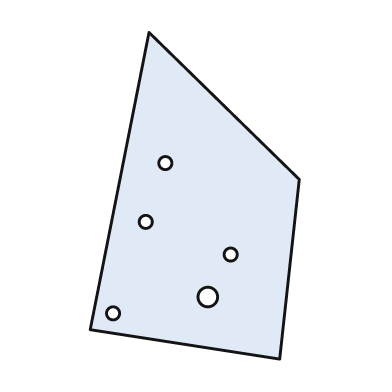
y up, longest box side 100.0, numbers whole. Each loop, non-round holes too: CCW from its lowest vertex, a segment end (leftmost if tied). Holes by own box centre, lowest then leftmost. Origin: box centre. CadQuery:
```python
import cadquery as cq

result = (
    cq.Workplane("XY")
    .moveTo(26.0, -50.0)
    .lineTo(32.0, 5.0)
    .lineTo(-14.0, 50.0)
    .lineTo(-32.0, -41.0)
    .close()
    .moveTo(-25.0, -36.0)
    .circle(2.0)
    .moveTo(4.0, -31.0)
    .circle(3.0)
    .moveTo(11.0, -18.0)
    .circle(2.0)
    .moveTo(-15.0, -8.0)
    .circle(2.0)
    .moveTo(-9.0, 10.0)
    .circle(2.0)
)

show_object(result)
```